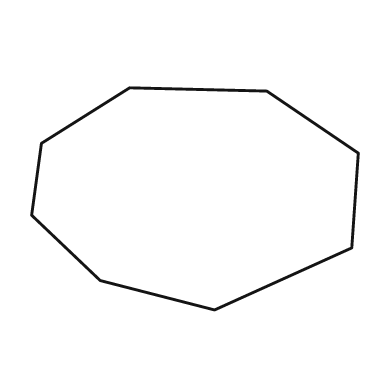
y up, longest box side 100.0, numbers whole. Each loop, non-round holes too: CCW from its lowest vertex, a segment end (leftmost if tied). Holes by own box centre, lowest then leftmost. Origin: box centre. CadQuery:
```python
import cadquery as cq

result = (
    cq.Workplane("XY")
    .moveTo(6.0, -34.0)
    .lineTo(48.0, -15.0)
    .lineTo(50.0, 14.0)
    .lineTo(22.0, 33.0)
    .lineTo(-20.0, 34.0)
    .lineTo(-47.0, 17.0)
    .lineTo(-50.0, -5.0)
    .lineTo(-29.0, -25.0)
    .close()
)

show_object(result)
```